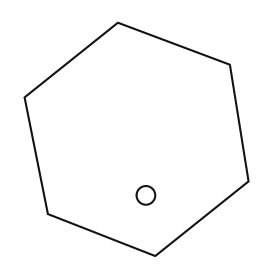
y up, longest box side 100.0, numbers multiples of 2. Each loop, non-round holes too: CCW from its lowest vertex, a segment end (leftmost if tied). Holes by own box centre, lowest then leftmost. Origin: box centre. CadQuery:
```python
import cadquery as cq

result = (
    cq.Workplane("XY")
    .moveTo(8.0, -50.0)
    .lineTo(48.0, -18.0)
    .lineTo(40.0, 32.0)
    .lineTo(-8.0, 50.0)
    .lineTo(-48.0, 18.0)
    .lineTo(-38.0, -32.0)
    .close()
    .moveTo(4.0, -24.0)
    .circle(4.0)
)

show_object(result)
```